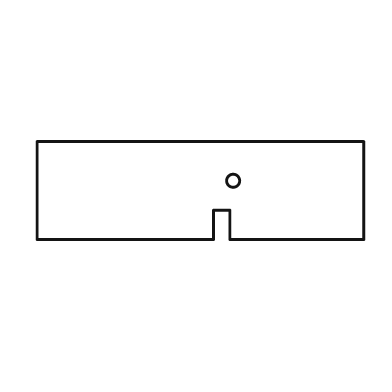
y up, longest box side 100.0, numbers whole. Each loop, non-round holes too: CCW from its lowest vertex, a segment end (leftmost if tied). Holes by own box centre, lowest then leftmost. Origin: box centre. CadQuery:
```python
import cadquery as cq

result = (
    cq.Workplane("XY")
    .moveTo(-50.0, -15.0)
    .lineTo(4.0, -15.0)
    .lineTo(4.0, -6.0)
    .lineTo(9.0, -6.0)
    .lineTo(9.0, -15.0)
    .lineTo(50.0, -15.0)
    .lineTo(50.0, 15.0)
    .lineTo(-50.0, 15.0)
    .close()
    .moveTo(10.0, 3.0)
    .circle(2.0)
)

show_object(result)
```